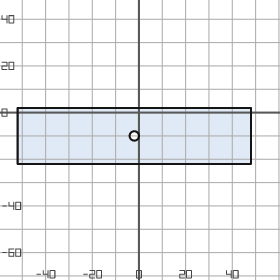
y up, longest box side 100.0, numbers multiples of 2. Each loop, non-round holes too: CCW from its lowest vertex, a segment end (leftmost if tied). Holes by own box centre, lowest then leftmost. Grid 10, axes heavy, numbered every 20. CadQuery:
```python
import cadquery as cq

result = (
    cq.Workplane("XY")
    .moveTo(-52.0, -22.0)
    .lineTo(48.0, -22.0)
    .lineTo(48.0, 2.0)
    .lineTo(-52.0, 2.0)
    .close()
    .moveTo(-2.0, -10.0)
    .circle(2.0)
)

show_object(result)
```